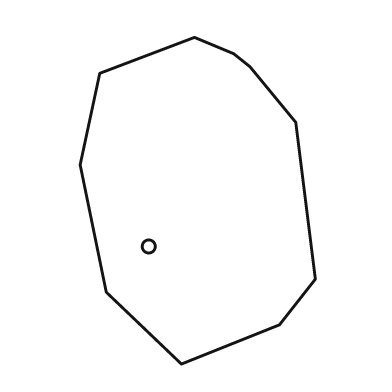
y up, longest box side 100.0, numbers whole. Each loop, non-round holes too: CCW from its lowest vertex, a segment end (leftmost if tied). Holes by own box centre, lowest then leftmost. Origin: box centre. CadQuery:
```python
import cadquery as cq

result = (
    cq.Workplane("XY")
    .moveTo(-5.0, -50.0)
    .lineTo(25.0, -38.0)
    .lineTo(36.0, -24.0)
    .lineTo(30.0, 24.0)
    .lineTo(16.0, 41.0)
    .lineTo(11.0, 45.0)
    .lineTo(-1.0, 50.0)
    .lineTo(-30.0, 39.0)
    .lineTo(-36.0, 11.0)
    .lineTo(-28.0, -28.0)
    .close()
    .moveTo(-15.0, -14.0)
    .circle(2.0)
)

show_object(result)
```